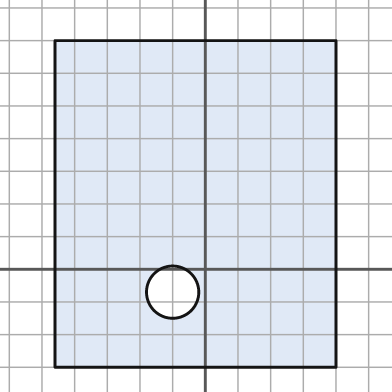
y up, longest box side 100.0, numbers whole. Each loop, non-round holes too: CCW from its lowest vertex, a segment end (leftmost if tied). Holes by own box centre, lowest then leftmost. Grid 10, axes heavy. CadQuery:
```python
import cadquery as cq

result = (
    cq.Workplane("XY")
    .moveTo(-46.0, -30.0)
    .lineTo(40.0, -30.0)
    .lineTo(40.0, 70.0)
    .lineTo(-46.0, 70.0)
    .close()
    .moveTo(-10.0, -7.0)
    .circle(8.0)
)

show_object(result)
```